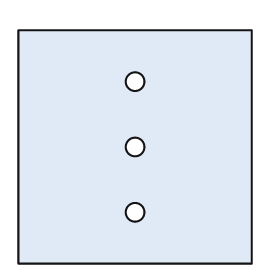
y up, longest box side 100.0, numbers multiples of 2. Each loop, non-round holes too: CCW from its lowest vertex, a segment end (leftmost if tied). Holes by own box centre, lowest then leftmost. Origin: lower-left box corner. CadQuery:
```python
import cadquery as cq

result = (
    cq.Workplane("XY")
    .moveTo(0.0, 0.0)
    .lineTo(100.0, 0.0)
    .lineTo(100.0, 100.0)
    .lineTo(0.0, 100.0)
    .close()
    .moveTo(50.0, 22.0)
    .circle(4.0)
    .moveTo(50.0, 50.0)
    .circle(4.0)
    .moveTo(50.0, 78.0)
    .circle(4.0)
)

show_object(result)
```